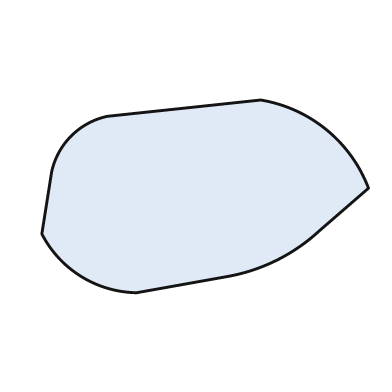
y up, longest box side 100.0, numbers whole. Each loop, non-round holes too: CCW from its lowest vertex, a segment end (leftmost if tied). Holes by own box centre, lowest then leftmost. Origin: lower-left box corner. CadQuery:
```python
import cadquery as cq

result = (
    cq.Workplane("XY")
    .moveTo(29.0, 0.0)
    .lineTo(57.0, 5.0)
    .threePointArc((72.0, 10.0), (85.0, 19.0))
    .lineTo(100.0, 32.0)
    .threePointArc((87.0, 50.0), (67.0, 59.0))
    .lineTo(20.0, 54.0)
    .threePointArc((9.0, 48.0), (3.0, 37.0))
    .lineTo(0.0, 18.0)
    .threePointArc((12.0, 5.0), (29.0, 0.0))
    .close()
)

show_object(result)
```